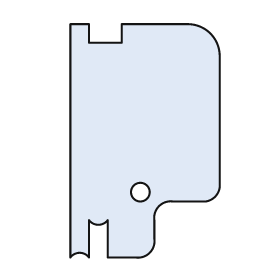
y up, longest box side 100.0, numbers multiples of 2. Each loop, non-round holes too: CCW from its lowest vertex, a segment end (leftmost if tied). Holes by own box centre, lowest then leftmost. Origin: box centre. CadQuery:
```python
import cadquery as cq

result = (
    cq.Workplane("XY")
    .moveTo(-32.0, -50.0)
    .threePointArc((-28.0, -48.0), (-24.0, -50.0))
    .lineTo(-24.0, -34.0)
    .threePointArc((-20.0, -36.0), (-16.0, -34.0))
    .lineTo(-16.0, -50.0)
    .lineTo(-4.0, -50.0)
    .threePointArc((2.0, -48.0), (4.0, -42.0))
    .lineTo(4.0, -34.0)
    .threePointArc((6.0, -28.0), (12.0, -26.0))
    .lineTo(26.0, -26.0)
    .threePointArc((30.0, -24.0), (32.0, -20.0))
    .lineTo(32.0, 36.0)
    .threePointArc((28.0, 46.0), (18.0, 50.0))
    .lineTo(-10.0, 50.0)
    .lineTo(-10.0, 42.0)
    .lineTo(-24.0, 42.0)
    .lineTo(-24.0, 50.0)
    .lineTo(-32.0, 50.0)
    .close()
    .moveTo(-2.0, -22.0)
    .circle(4.0)
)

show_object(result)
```